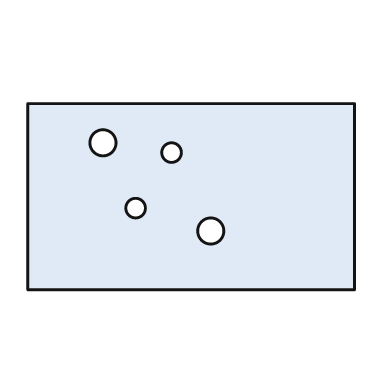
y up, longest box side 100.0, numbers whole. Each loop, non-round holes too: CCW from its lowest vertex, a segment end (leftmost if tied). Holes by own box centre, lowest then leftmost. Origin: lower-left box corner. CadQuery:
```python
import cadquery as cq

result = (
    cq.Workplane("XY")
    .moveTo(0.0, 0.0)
    .lineTo(100.0, 0.0)
    .lineTo(100.0, 57.0)
    .lineTo(0.0, 57.0)
    .close()
    .moveTo(56.0, 18.0)
    .circle(4.0)
    .moveTo(33.0, 25.0)
    .circle(3.0)
    .moveTo(44.0, 42.0)
    .circle(3.0)
    .moveTo(23.0, 45.0)
    .circle(4.0)
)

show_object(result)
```